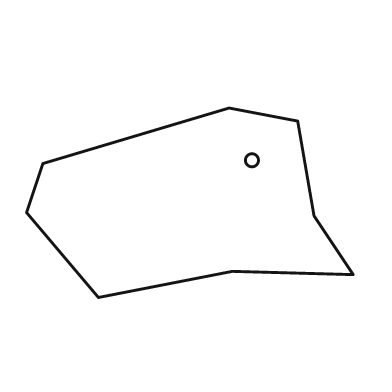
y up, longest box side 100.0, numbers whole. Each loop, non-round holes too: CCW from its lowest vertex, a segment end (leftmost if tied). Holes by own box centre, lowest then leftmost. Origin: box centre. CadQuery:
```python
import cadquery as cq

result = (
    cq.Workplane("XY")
    .moveTo(-28.0, -29.0)
    .lineTo(13.0, -21.0)
    .lineTo(50.0, -22.0)
    .lineTo(38.0, -4.0)
    .lineTo(33.0, 25.0)
    .lineTo(12.0, 29.0)
    .lineTo(-45.0, 12.0)
    .lineTo(-50.0, -3.0)
    .close()
    .moveTo(19.0, 13.0)
    .circle(2.0)
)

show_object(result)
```